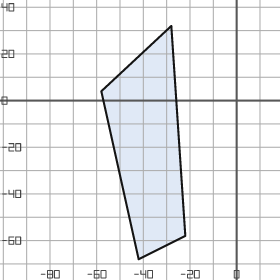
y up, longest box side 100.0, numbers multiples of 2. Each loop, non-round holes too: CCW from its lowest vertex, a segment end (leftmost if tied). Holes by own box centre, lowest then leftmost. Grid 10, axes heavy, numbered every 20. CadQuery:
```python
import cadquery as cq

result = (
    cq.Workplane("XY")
    .moveTo(-42.0, -68.0)
    .lineTo(-22.0, -58.0)
    .lineTo(-28.0, 32.0)
    .lineTo(-58.0, 4.0)
    .close()
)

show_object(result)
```